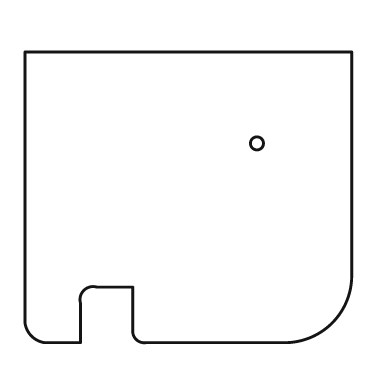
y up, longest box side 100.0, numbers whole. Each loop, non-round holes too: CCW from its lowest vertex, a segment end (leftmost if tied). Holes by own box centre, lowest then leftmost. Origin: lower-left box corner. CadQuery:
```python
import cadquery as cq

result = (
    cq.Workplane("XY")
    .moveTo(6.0, 0.0)
    .lineTo(17.0, 0.0)
    .lineTo(17.0, 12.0)
    .threePointArc((18.0, 16.0), (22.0, 17.0))
    .lineTo(33.0, 17.0)
    .lineTo(33.0, 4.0)
    .threePointArc((34.0, 1.0), (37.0, 0.0))
    .lineTo(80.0, 0.0)
    .threePointArc((94.0, 6.0), (100.0, 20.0))
    .lineTo(100.0, 89.0)
    .lineTo(0.0, 89.0)
    .lineTo(0.0, 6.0)
    .threePointArc((2.0, 2.0), (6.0, 0.0))
    .close()
    .moveTo(71.0, 61.0)
    .circle(2.0)
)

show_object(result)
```